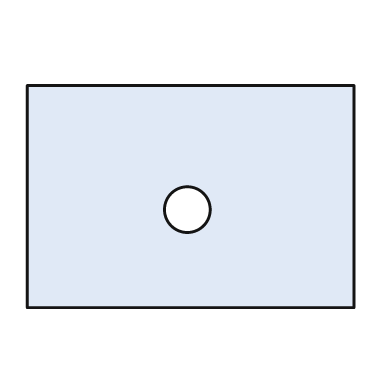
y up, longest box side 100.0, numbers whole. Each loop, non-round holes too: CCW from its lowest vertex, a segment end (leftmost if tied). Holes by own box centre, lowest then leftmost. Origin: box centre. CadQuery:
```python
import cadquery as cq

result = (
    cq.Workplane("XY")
    .moveTo(-50.0, -34.0)
    .lineTo(50.0, -34.0)
    .lineTo(50.0, 34.0)
    .lineTo(-50.0, 34.0)
    .close()
    .moveTo(-1.0, -4.0)
    .circle(7.0)
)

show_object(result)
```